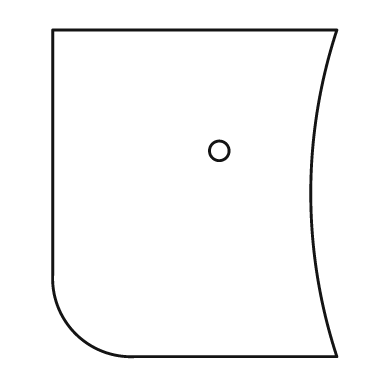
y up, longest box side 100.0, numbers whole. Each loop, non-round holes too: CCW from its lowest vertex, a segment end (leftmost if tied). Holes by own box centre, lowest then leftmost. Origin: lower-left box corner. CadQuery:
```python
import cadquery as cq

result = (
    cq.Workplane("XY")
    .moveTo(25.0, 0.0)
    .lineTo(87.0, 0.0)
    .threePointArc((79.0, 50.0), (87.0, 100.0))
    .lineTo(0.0, 100.0)
    .lineTo(0.0, 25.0)
    .threePointArc((7.0, 7.0), (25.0, 0.0))
    .close()
    .moveTo(51.0, 63.0)
    .circle(3.0)
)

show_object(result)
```